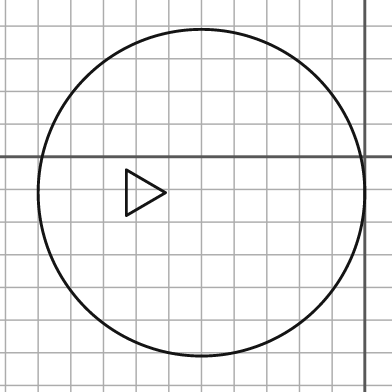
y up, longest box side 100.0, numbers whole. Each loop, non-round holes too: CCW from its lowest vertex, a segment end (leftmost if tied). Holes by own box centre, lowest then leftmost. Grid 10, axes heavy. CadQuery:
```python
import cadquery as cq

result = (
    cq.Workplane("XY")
    .moveTo(-50.0, -11.0)
    .circle(50.0)
    .moveTo(-73.0, -18.0)
    .lineTo(-61.0, -11.0)
    .lineTo(-73.0, -4.0)
    .close()
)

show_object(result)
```